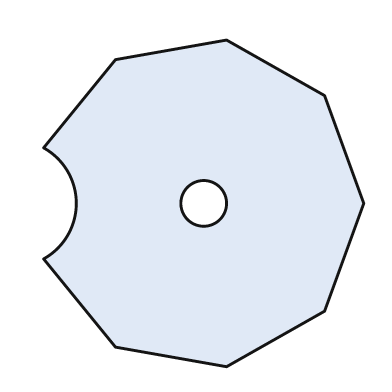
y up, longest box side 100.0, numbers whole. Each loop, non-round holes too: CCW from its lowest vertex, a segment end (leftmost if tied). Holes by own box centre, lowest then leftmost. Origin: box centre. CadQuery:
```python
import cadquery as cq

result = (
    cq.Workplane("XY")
    .moveTo(7.0, -50.0)
    .lineTo(37.0, -33.0)
    .lineTo(49.0, 0.0)
    .lineTo(37.0, 33.0)
    .lineTo(7.0, 50.0)
    .lineTo(-27.0, 44.0)
    .lineTo(-49.0, 17.0)
    .threePointArc((-39.0, 0.0), (-49.0, -17.0))
    .lineTo(-27.0, -44.0)
    .close()
    .moveTo(0.0, 0.0)
    .circle(7.0)
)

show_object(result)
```